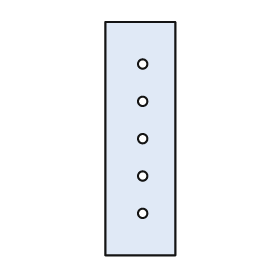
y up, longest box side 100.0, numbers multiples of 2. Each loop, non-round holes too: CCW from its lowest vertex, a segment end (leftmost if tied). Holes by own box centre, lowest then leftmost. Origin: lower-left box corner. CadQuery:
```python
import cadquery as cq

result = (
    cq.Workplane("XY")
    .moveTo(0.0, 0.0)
    .lineTo(30.0, 0.0)
    .lineTo(30.0, 100.0)
    .lineTo(0.0, 100.0)
    .close()
    .moveTo(16.0, 18.0)
    .circle(2.0)
    .moveTo(16.0, 34.0)
    .circle(2.0)
    .moveTo(16.0, 50.0)
    .circle(2.0)
    .moveTo(16.0, 66.0)
    .circle(2.0)
    .moveTo(16.0, 82.0)
    .circle(2.0)
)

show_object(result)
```